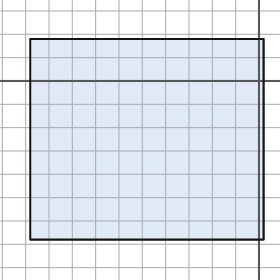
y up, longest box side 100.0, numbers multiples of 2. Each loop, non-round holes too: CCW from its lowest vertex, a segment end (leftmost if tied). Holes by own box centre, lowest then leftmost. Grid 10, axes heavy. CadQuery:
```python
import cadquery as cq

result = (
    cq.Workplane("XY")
    .moveTo(-98.0, -68.0)
    .lineTo(2.0, -68.0)
    .lineTo(2.0, 18.0)
    .lineTo(-98.0, 18.0)
    .close()
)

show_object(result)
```